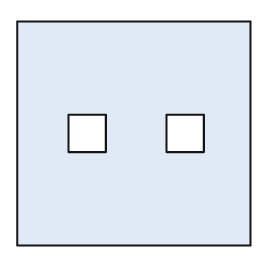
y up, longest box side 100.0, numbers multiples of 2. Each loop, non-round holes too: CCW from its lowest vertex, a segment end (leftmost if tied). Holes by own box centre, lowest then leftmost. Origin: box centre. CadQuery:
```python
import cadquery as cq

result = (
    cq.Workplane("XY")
    .moveTo(-50.0, -48.0)
    .lineTo(50.0, -48.0)
    .lineTo(50.0, 48.0)
    .lineTo(-50.0, 48.0)
    .close()
    .moveTo(-28.0, -8.0)
    .lineTo(-12.0, -8.0)
    .lineTo(-12.0, 8.0)
    .lineTo(-28.0, 8.0)
    .close()
    .moveTo(14.0, -8.0)
    .lineTo(30.0, -8.0)
    .lineTo(30.0, 8.0)
    .lineTo(14.0, 8.0)
    .close()
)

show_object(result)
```